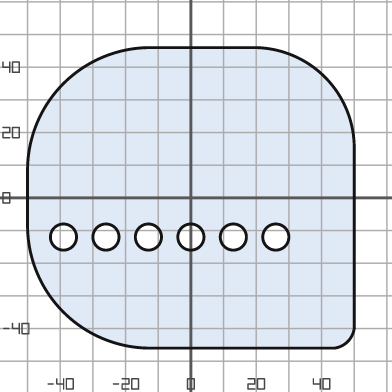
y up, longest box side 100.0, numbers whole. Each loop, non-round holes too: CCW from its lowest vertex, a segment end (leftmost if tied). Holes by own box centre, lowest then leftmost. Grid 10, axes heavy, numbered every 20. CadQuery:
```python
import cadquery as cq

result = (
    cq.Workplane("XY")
    .moveTo(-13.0, -46.0)
    .lineTo(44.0, -46.0)
    .threePointArc((48.0, -44.0), (50.0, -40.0))
    .lineTo(50.0, 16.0)
    .threePointArc((41.0, 37.0), (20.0, 46.0))
    .lineTo(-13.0, 46.0)
    .threePointArc((-39.0, 35.0), (-50.0, 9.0))
    .lineTo(-50.0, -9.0)
    .threePointArc((-39.0, -35.0), (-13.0, -46.0))
    .close()
    .moveTo(-39.0, -12.0)
    .circle(4.0)
    .moveTo(-26.0, -12.0)
    .circle(4.0)
    .moveTo(-13.0, -12.0)
    .circle(4.0)
    .moveTo(0.0, -12.0)
    .circle(4.0)
    .moveTo(13.0, -12.0)
    .circle(4.0)
    .moveTo(26.0, -12.0)
    .circle(4.0)
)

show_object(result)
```